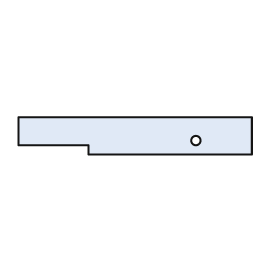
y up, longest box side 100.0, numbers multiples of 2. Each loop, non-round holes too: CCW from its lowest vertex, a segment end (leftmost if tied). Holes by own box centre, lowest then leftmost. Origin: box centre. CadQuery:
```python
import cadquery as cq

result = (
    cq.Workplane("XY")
    .moveTo(-20.0, -8.0)
    .lineTo(50.0, -8.0)
    .lineTo(50.0, 8.0)
    .lineTo(-50.0, 8.0)
    .lineTo(-50.0, -4.0)
    .lineTo(-20.0, -4.0)
    .close()
    .moveTo(26.0, -2.0)
    .circle(2.0)
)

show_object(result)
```